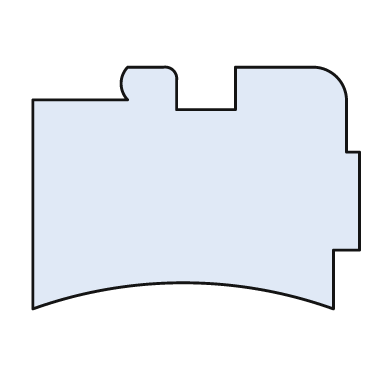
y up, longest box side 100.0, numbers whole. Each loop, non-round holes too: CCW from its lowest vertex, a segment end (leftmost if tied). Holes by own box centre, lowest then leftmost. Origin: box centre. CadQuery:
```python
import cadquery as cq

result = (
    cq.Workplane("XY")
    .moveTo(-50.0, -37.0)
    .threePointArc((-4.0, -29.0), (42.0, -37.0))
    .lineTo(42.0, -19.0)
    .lineTo(50.0, -19.0)
    .lineTo(50.0, 11.0)
    .lineTo(46.0, 11.0)
    .lineTo(46.0, 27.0)
    .threePointArc((43.0, 34.0), (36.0, 37.0))
    .lineTo(12.0, 37.0)
    .lineTo(12.0, 24.0)
    .lineTo(-6.0, 24.0)
    .lineTo(-6.0, 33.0)
    .threePointArc((-7.0, 36.0), (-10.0, 37.0))
    .lineTo(-21.0, 37.0)
    .threePointArc((-23.0, 32.0), (-21.0, 27.0))
    .lineTo(-50.0, 27.0)
    .close()
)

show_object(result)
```